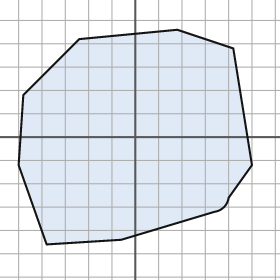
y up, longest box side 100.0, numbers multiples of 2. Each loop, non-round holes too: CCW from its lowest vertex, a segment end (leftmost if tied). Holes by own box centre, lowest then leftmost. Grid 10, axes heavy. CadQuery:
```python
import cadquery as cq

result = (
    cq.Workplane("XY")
    .moveTo(-38.0, -46.0)
    .lineTo(-6.0, -44.0)
    .lineTo(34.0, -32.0)
    .threePointArc((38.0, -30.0), (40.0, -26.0))
    .lineTo(50.0, -12.0)
    .lineTo(42.0, 38.0)
    .lineTo(18.0, 46.0)
    .lineTo(-24.0, 42.0)
    .lineTo(-48.0, 18.0)
    .lineTo(-50.0, -12.0)
    .close()
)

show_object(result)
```